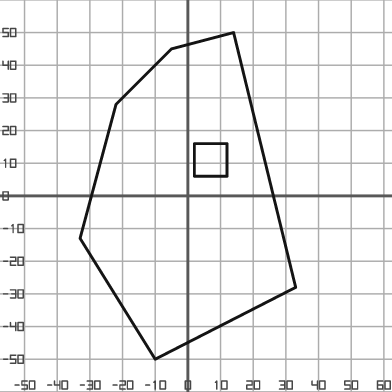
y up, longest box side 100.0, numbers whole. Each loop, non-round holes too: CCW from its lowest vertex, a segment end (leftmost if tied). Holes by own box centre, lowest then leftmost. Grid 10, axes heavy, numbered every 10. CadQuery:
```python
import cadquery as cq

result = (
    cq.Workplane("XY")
    .moveTo(-10.0, -50.0)
    .lineTo(33.0, -28.0)
    .lineTo(14.0, 50.0)
    .lineTo(-5.0, 45.0)
    .lineTo(-22.0, 28.0)
    .lineTo(-33.0, -13.0)
    .close()
    .moveTo(2.0, 6.0)
    .lineTo(12.0, 6.0)
    .lineTo(12.0, 16.0)
    .lineTo(2.0, 16.0)
    .close()
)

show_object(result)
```